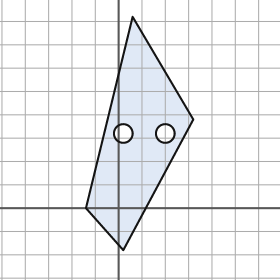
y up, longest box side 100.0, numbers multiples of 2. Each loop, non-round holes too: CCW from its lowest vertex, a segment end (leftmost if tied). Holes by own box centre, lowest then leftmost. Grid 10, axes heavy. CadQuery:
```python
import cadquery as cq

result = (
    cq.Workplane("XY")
    .moveTo(2.0, -18.0)
    .lineTo(32.0, 38.0)
    .lineTo(6.0, 82.0)
    .lineTo(-14.0, 0.0)
    .close()
    .moveTo(2.0, 32.0)
    .circle(4.0)
    .moveTo(20.0, 32.0)
    .circle(4.0)
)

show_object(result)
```